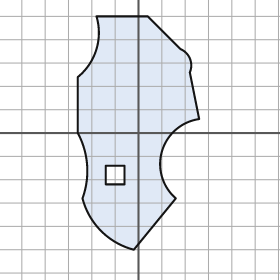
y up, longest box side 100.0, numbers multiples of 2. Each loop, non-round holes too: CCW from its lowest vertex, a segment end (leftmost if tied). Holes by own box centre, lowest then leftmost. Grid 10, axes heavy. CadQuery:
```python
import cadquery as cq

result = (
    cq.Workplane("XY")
    .moveTo(-2.0, -50.0)
    .lineTo(16.0, -28.0)
    .threePointArc((10.0, -8.0), (26.0, 6.0))
    .lineTo(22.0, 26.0)
    .threePointArc((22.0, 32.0), (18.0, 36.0))
    .lineTo(4.0, 50.0)
    .lineTo(-18.0, 50.0)
    .threePointArc((-18.0, 36.0), (-26.0, 24.0))
    .lineTo(-26.0, 0.0)
    .threePointArc((-22.0, -14.0), (-24.0, -28.0))
    .threePointArc((-16.0, -42.0), (-2.0, -50.0))
    .close()
    .moveTo(-14.0, -22.0)
    .lineTo(-6.0, -22.0)
    .lineTo(-6.0, -14.0)
    .lineTo(-14.0, -14.0)
    .close()
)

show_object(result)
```